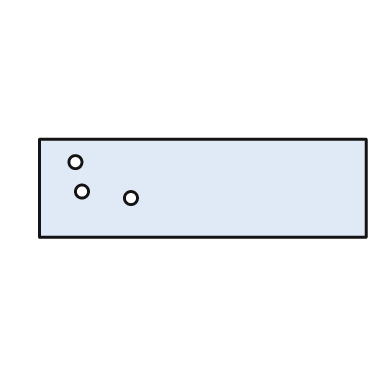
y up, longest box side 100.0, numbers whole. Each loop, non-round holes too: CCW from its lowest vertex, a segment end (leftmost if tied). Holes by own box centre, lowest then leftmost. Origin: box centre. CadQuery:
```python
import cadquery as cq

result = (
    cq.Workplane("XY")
    .moveTo(-50.0, -15.0)
    .lineTo(50.0, -15.0)
    .lineTo(50.0, 15.0)
    .lineTo(-50.0, 15.0)
    .close()
    .moveTo(-22.0, -3.0)
    .circle(2.0)
    .moveTo(-37.0, -1.0)
    .circle(2.0)
    .moveTo(-39.0, 8.0)
    .circle(2.0)
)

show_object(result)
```